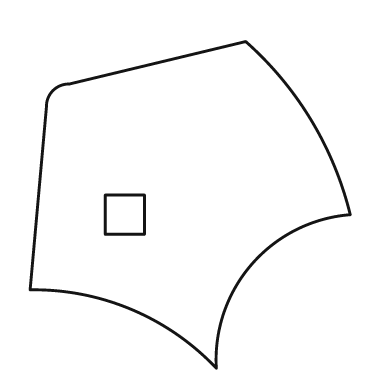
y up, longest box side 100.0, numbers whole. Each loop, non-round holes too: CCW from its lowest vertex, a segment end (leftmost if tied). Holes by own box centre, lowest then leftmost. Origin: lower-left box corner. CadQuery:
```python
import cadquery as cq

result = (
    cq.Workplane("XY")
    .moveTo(57.0, 0.0)
    .threePointArc((68.0, 32.0), (98.0, 47.0))
    .threePointArc((86.0, 76.0), (66.0, 100.0))
    .lineTo(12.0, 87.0)
    .threePointArc((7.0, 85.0), (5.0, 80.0))
    .lineTo(0.0, 24.0)
    .threePointArc((31.0, 18.0), (57.0, 0.0))
    .close()
    .moveTo(23.0, 41.0)
    .lineTo(35.0, 41.0)
    .lineTo(35.0, 53.0)
    .lineTo(23.0, 53.0)
    .close()
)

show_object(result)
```